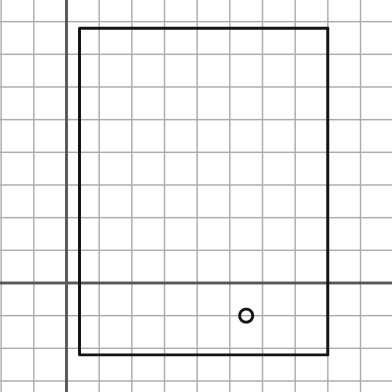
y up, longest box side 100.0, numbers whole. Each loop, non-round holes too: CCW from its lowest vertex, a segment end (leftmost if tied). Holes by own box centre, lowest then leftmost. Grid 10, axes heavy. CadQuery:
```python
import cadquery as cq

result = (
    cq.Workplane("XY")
    .moveTo(4.0, -22.0)
    .lineTo(80.0, -22.0)
    .lineTo(80.0, 78.0)
    .lineTo(4.0, 78.0)
    .close()
    .moveTo(55.0, -10.0)
    .circle(2.0)
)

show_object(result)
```